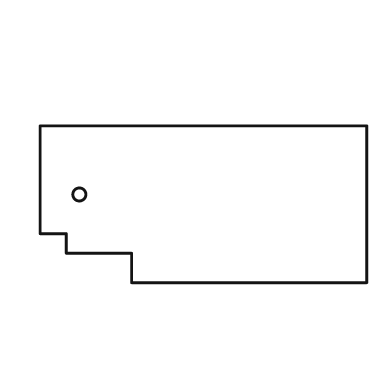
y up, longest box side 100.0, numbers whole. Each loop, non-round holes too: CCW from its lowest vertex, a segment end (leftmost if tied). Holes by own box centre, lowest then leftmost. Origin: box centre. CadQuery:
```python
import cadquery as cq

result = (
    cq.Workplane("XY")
    .moveTo(-22.0, -24.0)
    .lineTo(50.0, -24.0)
    .lineTo(50.0, 24.0)
    .lineTo(-50.0, 24.0)
    .lineTo(-50.0, -9.0)
    .lineTo(-42.0, -9.0)
    .lineTo(-42.0, -15.0)
    .lineTo(-22.0, -15.0)
    .close()
    .moveTo(-38.0, 3.0)
    .circle(2.0)
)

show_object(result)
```